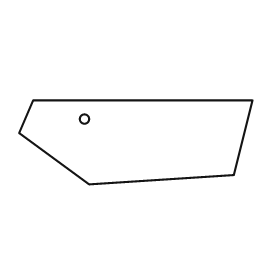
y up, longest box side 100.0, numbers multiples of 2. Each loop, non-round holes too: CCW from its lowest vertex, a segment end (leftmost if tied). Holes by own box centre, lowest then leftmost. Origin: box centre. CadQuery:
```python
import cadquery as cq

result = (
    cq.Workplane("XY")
    .moveTo(-20.0, -18.0)
    .lineTo(42.0, -14.0)
    .lineTo(50.0, 18.0)
    .lineTo(-44.0, 18.0)
    .lineTo(-50.0, 4.0)
    .close()
    .moveTo(-22.0, 10.0)
    .circle(2.0)
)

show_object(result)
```